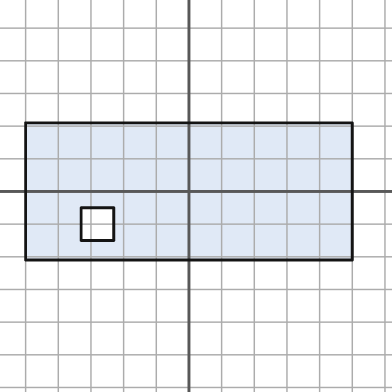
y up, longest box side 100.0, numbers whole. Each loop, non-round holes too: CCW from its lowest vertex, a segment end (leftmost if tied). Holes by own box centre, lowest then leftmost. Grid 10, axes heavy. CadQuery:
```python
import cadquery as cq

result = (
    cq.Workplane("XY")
    .moveTo(-50.0, -21.0)
    .lineTo(50.0, -21.0)
    .lineTo(50.0, 21.0)
    .lineTo(-50.0, 21.0)
    .close()
    .moveTo(-33.0, -15.0)
    .lineTo(-23.0, -15.0)
    .lineTo(-23.0, -5.0)
    .lineTo(-33.0, -5.0)
    .close()
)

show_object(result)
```